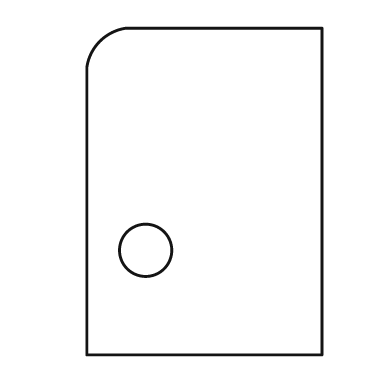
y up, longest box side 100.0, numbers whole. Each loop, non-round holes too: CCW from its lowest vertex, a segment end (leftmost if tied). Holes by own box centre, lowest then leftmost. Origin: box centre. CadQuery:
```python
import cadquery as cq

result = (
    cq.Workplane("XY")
    .moveTo(-36.0, -50.0)
    .lineTo(36.0, -50.0)
    .lineTo(36.0, 50.0)
    .lineTo(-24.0, 50.0)
    .threePointArc((-32.0, 46.0), (-36.0, 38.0))
    .close()
    .moveTo(-18.0, -18.0)
    .circle(8.0)
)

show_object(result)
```